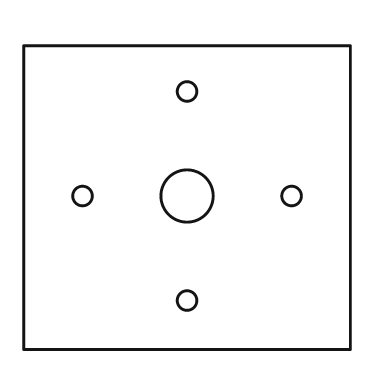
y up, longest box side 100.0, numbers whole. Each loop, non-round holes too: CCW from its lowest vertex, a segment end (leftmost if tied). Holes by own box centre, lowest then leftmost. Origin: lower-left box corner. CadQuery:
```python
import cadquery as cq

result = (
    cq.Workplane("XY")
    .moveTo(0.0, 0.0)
    .lineTo(100.0, 0.0)
    .lineTo(100.0, 93.0)
    .lineTo(0.0, 93.0)
    .close()
    .moveTo(50.0, 15.0)
    .circle(3.0)
    .moveTo(18.0, 47.0)
    .circle(3.0)
    .moveTo(50.0, 47.0)
    .circle(8.0)
    .moveTo(82.0, 47.0)
    .circle(3.0)
    .moveTo(50.0, 79.0)
    .circle(3.0)
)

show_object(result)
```